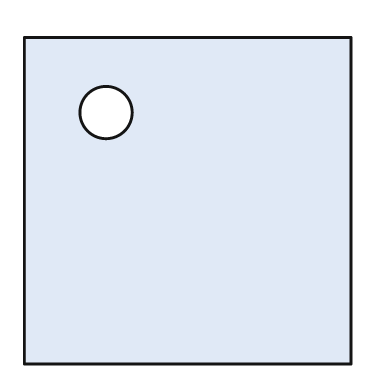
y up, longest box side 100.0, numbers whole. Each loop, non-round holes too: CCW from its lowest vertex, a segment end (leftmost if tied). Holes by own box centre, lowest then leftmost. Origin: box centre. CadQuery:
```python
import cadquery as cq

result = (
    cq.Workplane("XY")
    .moveTo(-50.0, -50.0)
    .lineTo(50.0, -50.0)
    .lineTo(50.0, 50.0)
    .lineTo(-50.0, 50.0)
    .close()
    .moveTo(-25.0, 27.0)
    .circle(8.0)
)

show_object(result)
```